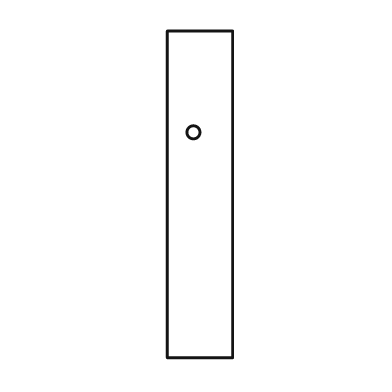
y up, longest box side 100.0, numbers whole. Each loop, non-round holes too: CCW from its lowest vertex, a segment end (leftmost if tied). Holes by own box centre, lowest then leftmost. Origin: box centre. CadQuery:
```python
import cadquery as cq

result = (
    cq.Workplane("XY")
    .moveTo(-10.0, -50.0)
    .lineTo(10.0, -50.0)
    .lineTo(10.0, 50.0)
    .lineTo(-10.0, 50.0)
    .close()
    .moveTo(-2.0, 19.0)
    .circle(2.0)
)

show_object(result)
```